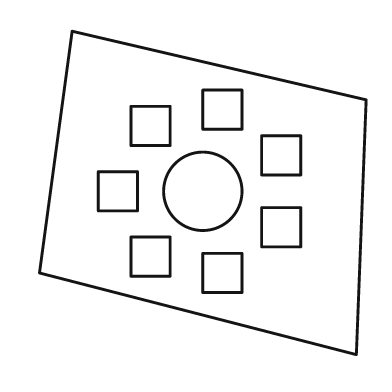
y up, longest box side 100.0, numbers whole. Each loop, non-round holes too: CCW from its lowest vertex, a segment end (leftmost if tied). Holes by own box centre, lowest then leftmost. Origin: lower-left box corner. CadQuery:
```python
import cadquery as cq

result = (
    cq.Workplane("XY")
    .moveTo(97.0, 0.0)
    .lineTo(100.0, 78.0)
    .lineTo(10.0, 99.0)
    .lineTo(0.0, 25.0)
    .close()
    .moveTo(50.0, 19.0)
    .lineTo(62.0, 19.0)
    .lineTo(62.0, 31.0)
    .lineTo(50.0, 31.0)
    .close()
    .moveTo(28.0, 24.0)
    .lineTo(40.0, 24.0)
    .lineTo(40.0, 36.0)
    .lineTo(28.0, 36.0)
    .close()
    .moveTo(68.0, 33.0)
    .lineTo(80.0, 33.0)
    .lineTo(80.0, 45.0)
    .lineTo(68.0, 45.0)
    .close()
    .moveTo(18.0, 44.0)
    .lineTo(30.0, 44.0)
    .lineTo(30.0, 56.0)
    .lineTo(18.0, 56.0)
    .close()
    .moveTo(50.0, 50.0)
    .circle(12.0)
    .moveTo(68.0, 55.0)
    .lineTo(80.0, 55.0)
    .lineTo(80.0, 67.0)
    .lineTo(68.0, 67.0)
    .close()
    .moveTo(28.0, 64.0)
    .lineTo(40.0, 64.0)
    .lineTo(40.0, 76.0)
    .lineTo(28.0, 76.0)
    .close()
    .moveTo(50.0, 69.0)
    .lineTo(62.0, 69.0)
    .lineTo(62.0, 81.0)
    .lineTo(50.0, 81.0)
    .close()
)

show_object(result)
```